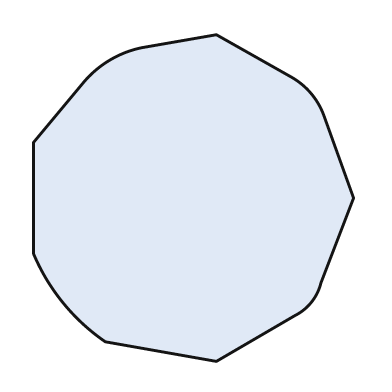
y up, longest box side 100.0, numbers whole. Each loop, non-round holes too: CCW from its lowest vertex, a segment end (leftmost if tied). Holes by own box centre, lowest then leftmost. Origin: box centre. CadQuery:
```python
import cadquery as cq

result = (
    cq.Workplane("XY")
    .moveTo(7.0, -50.0)
    .lineTo(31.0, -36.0)
    .threePointArc((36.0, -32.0), (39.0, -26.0))
    .lineTo(49.0, 0.0)
    .lineTo(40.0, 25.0)
    .threePointArc((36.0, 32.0), (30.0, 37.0))
    .lineTo(7.0, 50.0)
    .lineTo(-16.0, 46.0)
    .threePointArc((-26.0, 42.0), (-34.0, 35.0))
    .lineTo(-49.0, 17.0)
    .lineTo(-49.0, -17.0)
    .threePointArc((-40.0, -32.0), (-27.0, -44.0))
    .close()
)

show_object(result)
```